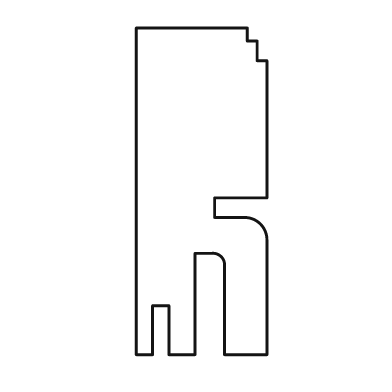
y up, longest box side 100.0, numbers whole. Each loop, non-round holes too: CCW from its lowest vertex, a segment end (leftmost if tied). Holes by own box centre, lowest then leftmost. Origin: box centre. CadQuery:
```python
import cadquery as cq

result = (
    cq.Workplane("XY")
    .moveTo(-20.0, -50.0)
    .lineTo(-15.0, -50.0)
    .lineTo(-15.0, -35.0)
    .lineTo(-10.0, -35.0)
    .lineTo(-10.0, -50.0)
    .lineTo(-2.0, -50.0)
    .lineTo(-2.0, -19.0)
    .lineTo(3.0, -19.0)
    .threePointArc((6.0, -20.0), (7.0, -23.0))
    .lineTo(7.0, -50.0)
    .lineTo(20.0, -50.0)
    .lineTo(20.0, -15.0)
    .threePointArc((18.0, -10.0), (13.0, -8.0))
    .lineTo(4.0, -8.0)
    .lineTo(4.0, -2.0)
    .lineTo(20.0, -2.0)
    .lineTo(20.0, 40.0)
    .lineTo(17.0, 40.0)
    .lineTo(17.0, 46.0)
    .lineTo(14.0, 46.0)
    .lineTo(14.0, 50.0)
    .lineTo(-20.0, 50.0)
    .close()
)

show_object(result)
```